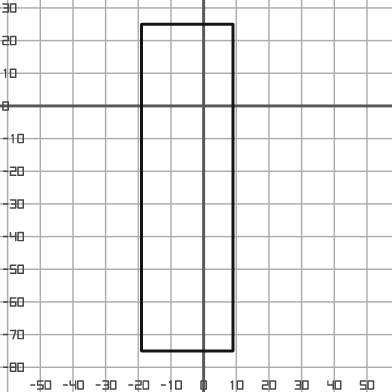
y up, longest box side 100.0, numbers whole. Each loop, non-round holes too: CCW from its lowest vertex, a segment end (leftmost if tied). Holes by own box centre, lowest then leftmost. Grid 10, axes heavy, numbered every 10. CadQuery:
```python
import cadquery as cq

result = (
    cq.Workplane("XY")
    .moveTo(-19.0, -75.0)
    .lineTo(9.0, -75.0)
    .lineTo(9.0, 25.0)
    .lineTo(-19.0, 25.0)
    .close()
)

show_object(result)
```